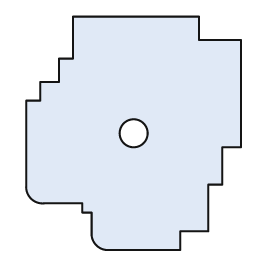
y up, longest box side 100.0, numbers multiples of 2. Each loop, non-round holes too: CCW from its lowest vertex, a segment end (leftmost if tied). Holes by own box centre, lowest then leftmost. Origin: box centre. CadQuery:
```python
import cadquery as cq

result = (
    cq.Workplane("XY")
    .moveTo(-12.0, -50.0)
    .lineTo(20.0, -50.0)
    .lineTo(20.0, -42.0)
    .lineTo(32.0, -42.0)
    .lineTo(32.0, -22.0)
    .lineTo(38.0, -22.0)
    .lineTo(38.0, -6.0)
    .lineTo(46.0, -6.0)
    .lineTo(46.0, 40.0)
    .lineTo(28.0, 40.0)
    .lineTo(28.0, 50.0)
    .lineTo(-26.0, 50.0)
    .lineTo(-26.0, 32.0)
    .lineTo(-32.0, 32.0)
    .lineTo(-32.0, 22.0)
    .lineTo(-40.0, 22.0)
    .lineTo(-40.0, 14.0)
    .lineTo(-46.0, 14.0)
    .lineTo(-46.0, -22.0)
    .threePointArc((-44.0, -28.0), (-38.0, -30.0))
    .lineTo(-22.0, -30.0)
    .lineTo(-22.0, -34.0)
    .lineTo(-18.0, -34.0)
    .lineTo(-18.0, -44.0)
    .threePointArc((-16.0, -48.0), (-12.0, -50.0))
    .close()
    .moveTo(0.0, 0.0)
    .circle(6.0)
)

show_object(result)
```